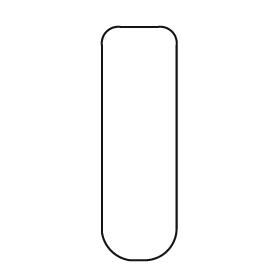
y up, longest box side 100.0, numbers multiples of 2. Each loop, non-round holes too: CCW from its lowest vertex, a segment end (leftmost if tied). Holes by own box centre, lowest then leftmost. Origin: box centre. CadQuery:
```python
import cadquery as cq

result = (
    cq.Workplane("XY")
    .moveTo(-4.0, -50.0)
    .lineTo(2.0, -50.0)
    .threePointArc((12.0, -46.0), (16.0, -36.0))
    .lineTo(16.0, 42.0)
    .threePointArc((14.0, 48.0), (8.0, 50.0))
    .lineTo(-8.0, 50.0)
    .threePointArc((-14.0, 48.0), (-16.0, 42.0))
    .lineTo(-16.0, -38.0)
    .threePointArc((-12.0, -46.0), (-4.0, -50.0))
    .close()
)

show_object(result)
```